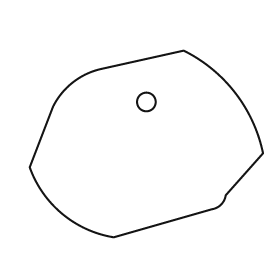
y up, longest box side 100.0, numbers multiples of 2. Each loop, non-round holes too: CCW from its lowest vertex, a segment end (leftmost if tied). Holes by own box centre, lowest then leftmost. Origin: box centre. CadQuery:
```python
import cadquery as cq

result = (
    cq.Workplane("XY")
    .moveTo(-14.0, -40.0)
    .lineTo(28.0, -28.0)
    .threePointArc((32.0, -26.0), (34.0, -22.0))
    .lineTo(50.0, -4.0)
    .threePointArc((38.0, 22.0), (16.0, 40.0))
    .lineTo(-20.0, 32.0)
    .threePointArc((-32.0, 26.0), (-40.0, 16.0))
    .lineTo(-50.0, -10.0)
    .threePointArc((-36.0, -30.0), (-14.0, -40.0))
    .close()
    .moveTo(0.0, 18.0)
    .circle(4.0)
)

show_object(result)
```